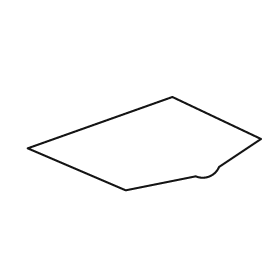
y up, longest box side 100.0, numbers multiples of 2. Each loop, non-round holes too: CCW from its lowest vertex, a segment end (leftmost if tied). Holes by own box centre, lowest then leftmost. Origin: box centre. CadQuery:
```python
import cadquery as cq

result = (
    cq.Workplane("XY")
    .moveTo(-8.0, -20.0)
    .lineTo(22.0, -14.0)
    .threePointArc((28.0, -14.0), (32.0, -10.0))
    .lineTo(50.0, 2.0)
    .lineTo(12.0, 20.0)
    .lineTo(-50.0, -2.0)
    .close()
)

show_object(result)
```